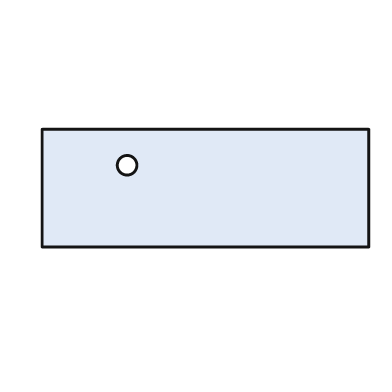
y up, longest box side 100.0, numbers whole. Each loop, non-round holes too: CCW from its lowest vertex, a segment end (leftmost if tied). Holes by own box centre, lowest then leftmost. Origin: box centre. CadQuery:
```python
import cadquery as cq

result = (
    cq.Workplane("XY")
    .moveTo(-50.0, -18.0)
    .lineTo(50.0, -18.0)
    .lineTo(50.0, 18.0)
    .lineTo(-50.0, 18.0)
    .close()
    .moveTo(-24.0, 7.0)
    .circle(3.0)
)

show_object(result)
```